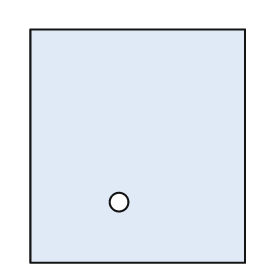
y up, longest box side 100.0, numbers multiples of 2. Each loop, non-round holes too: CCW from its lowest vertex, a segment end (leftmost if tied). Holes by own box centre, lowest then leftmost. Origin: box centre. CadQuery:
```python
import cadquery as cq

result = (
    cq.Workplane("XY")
    .moveTo(-46.0, -50.0)
    .lineTo(46.0, -50.0)
    .lineTo(46.0, 50.0)
    .lineTo(-46.0, 50.0)
    .close()
    .moveTo(-8.0, -24.0)
    .circle(4.0)
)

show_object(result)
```